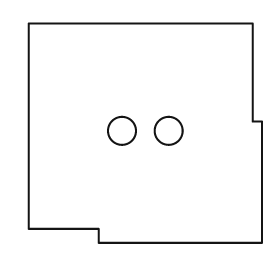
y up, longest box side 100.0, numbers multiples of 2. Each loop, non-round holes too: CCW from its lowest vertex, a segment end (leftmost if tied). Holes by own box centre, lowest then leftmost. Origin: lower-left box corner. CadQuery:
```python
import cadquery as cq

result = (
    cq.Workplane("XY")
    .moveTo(30.0, 0.0)
    .lineTo(100.0, 0.0)
    .lineTo(100.0, 52.0)
    .lineTo(96.0, 52.0)
    .lineTo(96.0, 94.0)
    .lineTo(0.0, 94.0)
    .lineTo(0.0, 6.0)
    .lineTo(30.0, 6.0)
    .close()
    .moveTo(40.0, 48.0)
    .circle(6.0)
    .moveTo(60.0, 48.0)
    .circle(6.0)
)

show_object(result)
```